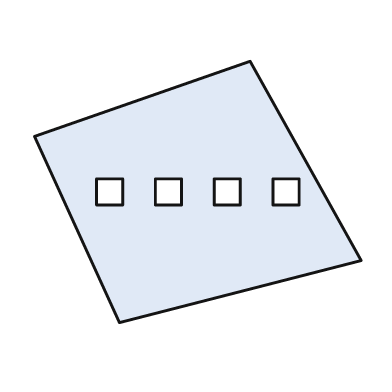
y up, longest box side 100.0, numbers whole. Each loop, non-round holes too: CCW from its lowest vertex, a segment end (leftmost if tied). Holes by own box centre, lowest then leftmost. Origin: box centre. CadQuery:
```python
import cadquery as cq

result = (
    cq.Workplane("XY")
    .moveTo(-24.0, -40.0)
    .lineTo(50.0, -21.0)
    .lineTo(16.0, 40.0)
    .lineTo(-50.0, 17.0)
    .close()
    .moveTo(-31.0, -4.0)
    .lineTo(-23.0, -4.0)
    .lineTo(-23.0, 4.0)
    .lineTo(-31.0, 4.0)
    .close()
    .moveTo(-13.0, -4.0)
    .lineTo(-5.0, -4.0)
    .lineTo(-5.0, 4.0)
    .lineTo(-13.0, 4.0)
    .close()
    .moveTo(5.0, -4.0)
    .lineTo(13.0, -4.0)
    .lineTo(13.0, 4.0)
    .lineTo(5.0, 4.0)
    .close()
    .moveTo(23.0, -4.0)
    .lineTo(31.0, -4.0)
    .lineTo(31.0, 4.0)
    .lineTo(23.0, 4.0)
    .close()
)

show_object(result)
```